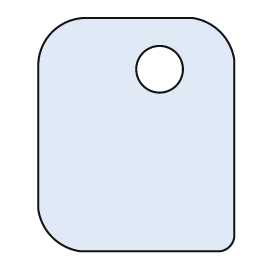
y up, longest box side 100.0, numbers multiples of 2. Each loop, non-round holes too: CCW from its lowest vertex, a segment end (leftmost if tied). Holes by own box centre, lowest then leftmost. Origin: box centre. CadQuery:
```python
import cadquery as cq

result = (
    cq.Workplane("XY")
    .moveTo(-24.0, -50.0)
    .lineTo(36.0, -50.0)
    .threePointArc((40.0, -48.0), (42.0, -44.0))
    .lineTo(42.0, 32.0)
    .threePointArc((36.0, 44.0), (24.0, 50.0))
    .lineTo(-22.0, 50.0)
    .threePointArc((-36.0, 44.0), (-42.0, 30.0))
    .lineTo(-42.0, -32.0)
    .threePointArc((-36.0, -44.0), (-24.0, -50.0))
    .close()
    .moveTo(10.0, 28.0)
    .circle(10.0)
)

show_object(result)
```